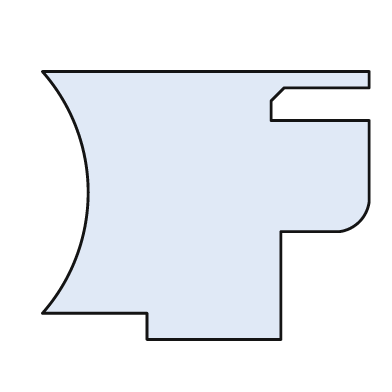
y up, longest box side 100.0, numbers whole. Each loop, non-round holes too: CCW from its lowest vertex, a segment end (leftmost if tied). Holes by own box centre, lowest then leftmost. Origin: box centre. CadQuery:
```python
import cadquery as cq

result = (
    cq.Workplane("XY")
    .moveTo(-18.0, -41.0)
    .lineTo(23.0, -41.0)
    .lineTo(23.0, -8.0)
    .lineTo(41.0, -8.0)
    .threePointArc((47.0, -5.0), (50.0, 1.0))
    .lineTo(50.0, 26.0)
    .lineTo(20.0, 26.0)
    .lineTo(20.0, 32.0)
    .lineTo(24.0, 36.0)
    .lineTo(50.0, 36.0)
    .lineTo(50.0, 41.0)
    .lineTo(-50.0, 41.0)
    .threePointArc((-36.0, 4.0), (-50.0, -33.0))
    .lineTo(-18.0, -33.0)
    .close()
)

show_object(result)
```